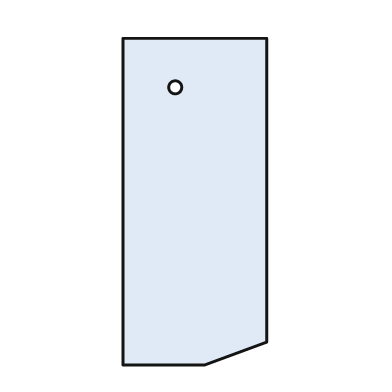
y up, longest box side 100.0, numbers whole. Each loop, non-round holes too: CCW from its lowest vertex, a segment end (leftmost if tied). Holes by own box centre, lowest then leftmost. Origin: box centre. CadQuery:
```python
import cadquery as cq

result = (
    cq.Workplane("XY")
    .moveTo(-22.0, -50.0)
    .lineTo(3.0, -50.0)
    .lineTo(22.0, -43.0)
    .lineTo(22.0, 50.0)
    .lineTo(-22.0, 50.0)
    .close()
    .moveTo(-6.0, 35.0)
    .circle(2.0)
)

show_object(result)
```